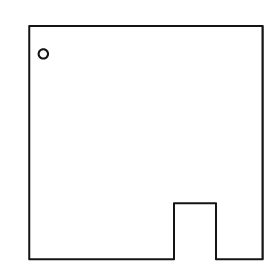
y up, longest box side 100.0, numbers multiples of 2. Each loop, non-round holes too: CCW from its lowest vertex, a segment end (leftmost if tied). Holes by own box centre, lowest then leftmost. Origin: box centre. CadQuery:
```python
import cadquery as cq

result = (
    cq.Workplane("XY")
    .moveTo(-50.0, -50.0)
    .lineTo(12.0, -50.0)
    .lineTo(12.0, -26.0)
    .lineTo(30.0, -26.0)
    .lineTo(30.0, -50.0)
    .lineTo(50.0, -50.0)
    .lineTo(50.0, 50.0)
    .lineTo(-50.0, 50.0)
    .close()
    .moveTo(-44.0, 38.0)
    .circle(2.0)
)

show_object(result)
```